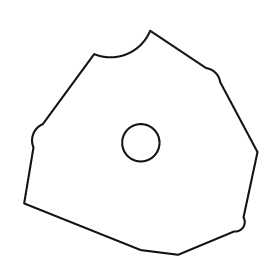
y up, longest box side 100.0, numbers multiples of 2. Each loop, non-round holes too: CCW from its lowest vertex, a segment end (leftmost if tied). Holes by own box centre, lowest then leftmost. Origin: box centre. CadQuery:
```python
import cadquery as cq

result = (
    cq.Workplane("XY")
    .moveTo(16.0, -48.0)
    .lineTo(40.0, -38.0)
    .threePointArc((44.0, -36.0), (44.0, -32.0))
    .lineTo(50.0, -4.0)
    .lineTo(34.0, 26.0)
    .threePointArc((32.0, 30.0), (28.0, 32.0))
    .lineTo(4.0, 48.0)
    .threePointArc((-6.0, 38.0), (-20.0, 38.0))
    .lineTo(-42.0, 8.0)
    .threePointArc((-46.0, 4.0), (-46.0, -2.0))
    .lineTo(-50.0, -26.0)
    .lineTo(0.0, -46.0)
    .close()
    .moveTo(0.0, 0.0)
    .circle(8.0)
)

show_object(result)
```